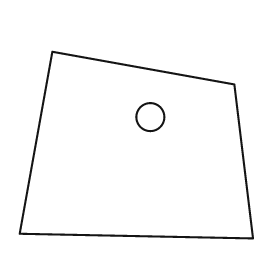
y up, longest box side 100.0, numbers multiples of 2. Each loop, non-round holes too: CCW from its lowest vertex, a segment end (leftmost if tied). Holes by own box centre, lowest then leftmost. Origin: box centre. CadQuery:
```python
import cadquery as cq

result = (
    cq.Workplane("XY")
    .moveTo(50.0, -40.0)
    .lineTo(42.0, 26.0)
    .lineTo(-36.0, 40.0)
    .lineTo(-50.0, -38.0)
    .close()
    .moveTo(6.0, 12.0)
    .circle(6.0)
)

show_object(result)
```